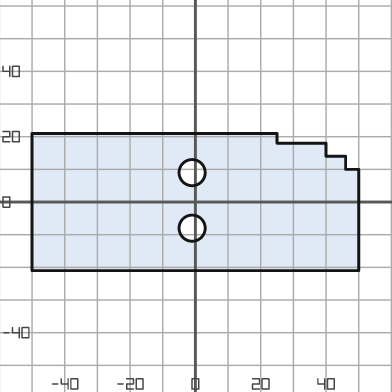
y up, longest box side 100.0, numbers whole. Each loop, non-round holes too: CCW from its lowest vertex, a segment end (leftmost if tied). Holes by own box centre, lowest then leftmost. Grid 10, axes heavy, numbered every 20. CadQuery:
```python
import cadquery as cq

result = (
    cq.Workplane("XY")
    .moveTo(-50.0, -21.0)
    .lineTo(50.0, -21.0)
    .lineTo(50.0, 10.0)
    .lineTo(46.0, 10.0)
    .lineTo(46.0, 14.0)
    .lineTo(40.0, 14.0)
    .lineTo(40.0, 18.0)
    .lineTo(25.0, 18.0)
    .lineTo(25.0, 21.0)
    .lineTo(-50.0, 21.0)
    .close()
    .moveTo(-1.0, -8.0)
    .circle(4.0)
    .moveTo(-1.0, 9.0)
    .circle(4.0)
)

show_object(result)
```